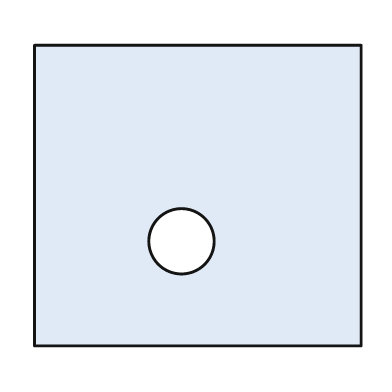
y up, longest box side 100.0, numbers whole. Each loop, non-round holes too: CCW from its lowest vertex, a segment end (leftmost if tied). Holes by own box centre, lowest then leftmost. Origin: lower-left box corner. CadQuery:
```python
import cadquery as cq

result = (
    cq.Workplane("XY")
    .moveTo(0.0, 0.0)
    .lineTo(100.0, 0.0)
    .lineTo(100.0, 92.0)
    .lineTo(0.0, 92.0)
    .close()
    .moveTo(45.0, 32.0)
    .circle(10.0)
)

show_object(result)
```